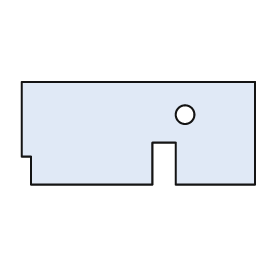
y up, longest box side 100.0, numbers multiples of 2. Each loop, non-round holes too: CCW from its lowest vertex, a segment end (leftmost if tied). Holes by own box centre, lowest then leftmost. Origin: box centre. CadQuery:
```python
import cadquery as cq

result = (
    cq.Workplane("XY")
    .moveTo(-46.0, -22.0)
    .lineTo(6.0, -22.0)
    .lineTo(6.0, -4.0)
    .lineTo(16.0, -4.0)
    .lineTo(16.0, -22.0)
    .lineTo(50.0, -22.0)
    .lineTo(50.0, 22.0)
    .lineTo(-50.0, 22.0)
    .lineTo(-50.0, -10.0)
    .lineTo(-46.0, -10.0)
    .close()
    .moveTo(20.0, 8.0)
    .circle(4.0)
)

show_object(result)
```